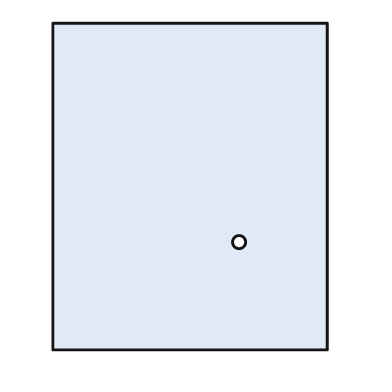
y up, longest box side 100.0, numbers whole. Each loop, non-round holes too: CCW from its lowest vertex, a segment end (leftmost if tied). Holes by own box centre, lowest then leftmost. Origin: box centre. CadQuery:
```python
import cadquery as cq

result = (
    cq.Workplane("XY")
    .moveTo(-42.0, -50.0)
    .lineTo(42.0, -50.0)
    .lineTo(42.0, 50.0)
    .lineTo(-42.0, 50.0)
    .close()
    .moveTo(15.0, -17.0)
    .circle(2.0)
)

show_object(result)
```